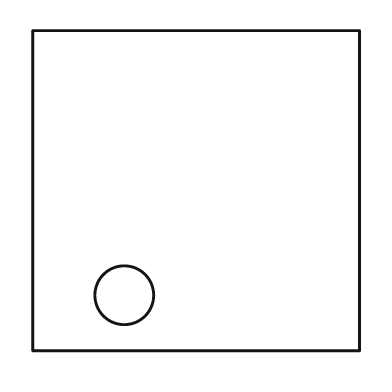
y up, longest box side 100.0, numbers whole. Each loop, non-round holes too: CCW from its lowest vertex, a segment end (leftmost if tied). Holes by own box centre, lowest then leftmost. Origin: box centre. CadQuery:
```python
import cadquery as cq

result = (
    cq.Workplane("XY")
    .moveTo(-50.0, -49.0)
    .lineTo(50.0, -49.0)
    .lineTo(50.0, 49.0)
    .lineTo(-50.0, 49.0)
    .close()
    .moveTo(-22.0, -32.0)
    .circle(9.0)
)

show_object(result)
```